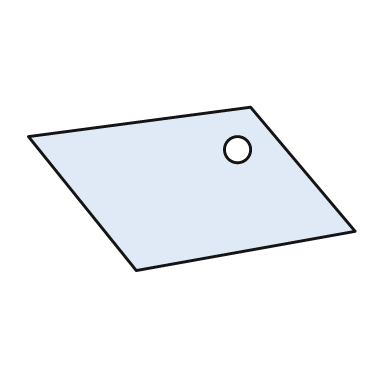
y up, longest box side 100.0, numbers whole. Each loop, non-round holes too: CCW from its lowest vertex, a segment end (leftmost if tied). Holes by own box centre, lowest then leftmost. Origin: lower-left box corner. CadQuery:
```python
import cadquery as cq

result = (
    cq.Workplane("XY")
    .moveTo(33.0, 0.0)
    .lineTo(100.0, 12.0)
    .lineTo(68.0, 50.0)
    .lineTo(0.0, 41.0)
    .close()
    .moveTo(64.0, 37.0)
    .circle(4.0)
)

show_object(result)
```